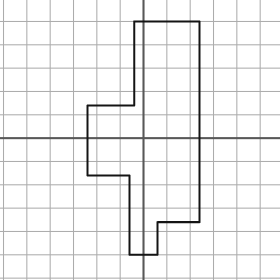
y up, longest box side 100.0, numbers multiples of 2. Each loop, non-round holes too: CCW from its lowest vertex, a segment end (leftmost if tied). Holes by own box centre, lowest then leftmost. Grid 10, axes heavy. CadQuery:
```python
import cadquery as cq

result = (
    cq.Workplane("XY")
    .moveTo(-6.0, -50.0)
    .lineTo(6.0, -50.0)
    .lineTo(6.0, -36.0)
    .lineTo(24.0, -36.0)
    .lineTo(24.0, 50.0)
    .lineTo(-4.0, 50.0)
    .lineTo(-4.0, 14.0)
    .lineTo(-24.0, 14.0)
    .lineTo(-24.0, -16.0)
    .lineTo(-6.0, -16.0)
    .close()
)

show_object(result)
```